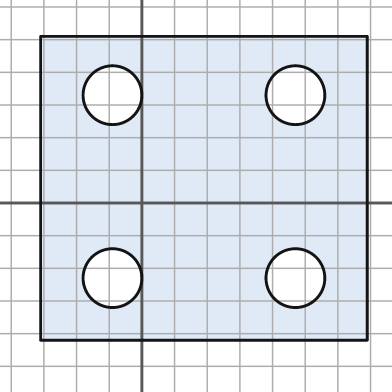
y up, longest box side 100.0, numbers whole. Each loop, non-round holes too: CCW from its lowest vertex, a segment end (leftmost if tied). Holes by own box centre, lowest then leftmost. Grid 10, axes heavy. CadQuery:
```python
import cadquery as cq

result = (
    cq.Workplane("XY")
    .moveTo(-31.0, -42.0)
    .lineTo(69.0, -42.0)
    .lineTo(69.0, 51.0)
    .lineTo(-31.0, 51.0)
    .close()
    .moveTo(-9.0, -23.0)
    .circle(9.0)
    .moveTo(47.0, -23.0)
    .circle(9.0)
    .moveTo(-9.0, 33.0)
    .circle(9.0)
    .moveTo(47.0, 33.0)
    .circle(9.0)
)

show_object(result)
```